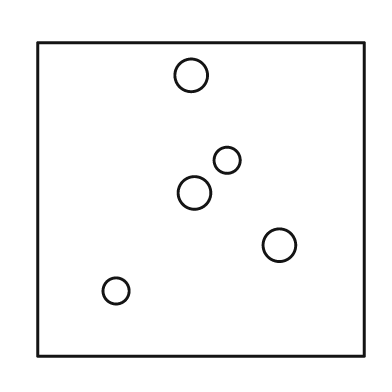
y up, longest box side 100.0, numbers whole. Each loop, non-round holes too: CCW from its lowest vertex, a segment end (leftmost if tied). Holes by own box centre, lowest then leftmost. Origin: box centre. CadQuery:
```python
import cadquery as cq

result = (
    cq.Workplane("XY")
    .moveTo(-50.0, -48.0)
    .lineTo(50.0, -48.0)
    .lineTo(50.0, 48.0)
    .lineTo(-50.0, 48.0)
    .close()
    .moveTo(-26.0, -28.0)
    .circle(4.0)
    .moveTo(24.0, -14.0)
    .circle(5.0)
    .moveTo(-2.0, 2.0)
    .circle(5.0)
    .moveTo(8.0, 12.0)
    .circle(4.0)
    .moveTo(-3.0, 38.0)
    .circle(5.0)
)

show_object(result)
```